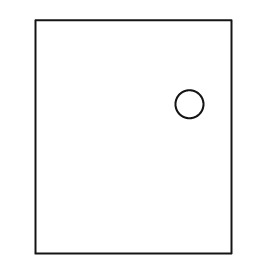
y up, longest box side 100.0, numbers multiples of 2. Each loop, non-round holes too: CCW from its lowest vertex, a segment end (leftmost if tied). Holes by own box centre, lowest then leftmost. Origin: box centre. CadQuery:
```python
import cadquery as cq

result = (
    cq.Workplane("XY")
    .moveTo(-42.0, -50.0)
    .lineTo(42.0, -50.0)
    .lineTo(42.0, 50.0)
    .lineTo(-42.0, 50.0)
    .close()
    .moveTo(24.0, 14.0)
    .circle(6.0)
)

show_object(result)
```